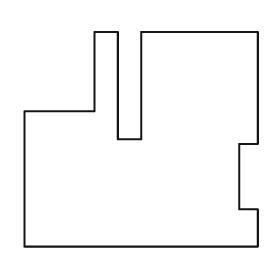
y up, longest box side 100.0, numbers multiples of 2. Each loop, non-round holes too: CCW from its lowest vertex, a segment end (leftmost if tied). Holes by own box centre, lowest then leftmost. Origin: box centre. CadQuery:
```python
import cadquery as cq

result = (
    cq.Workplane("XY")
    .moveTo(-50.0, -46.0)
    .lineTo(50.0, -46.0)
    .lineTo(50.0, -30.0)
    .lineTo(42.0, -30.0)
    .lineTo(42.0, -2.0)
    .lineTo(50.0, -2.0)
    .lineTo(50.0, 46.0)
    .lineTo(0.0, 46.0)
    .lineTo(0.0, 0.0)
    .lineTo(-10.0, 0.0)
    .lineTo(-10.0, 46.0)
    .lineTo(-20.0, 46.0)
    .lineTo(-20.0, 12.0)
    .lineTo(-50.0, 12.0)
    .close()
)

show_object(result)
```